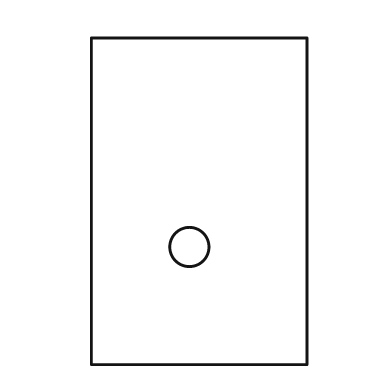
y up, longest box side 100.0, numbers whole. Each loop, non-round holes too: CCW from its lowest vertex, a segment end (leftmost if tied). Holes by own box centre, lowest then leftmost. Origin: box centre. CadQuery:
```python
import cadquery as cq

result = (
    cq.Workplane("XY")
    .moveTo(-33.0, -50.0)
    .lineTo(33.0, -50.0)
    .lineTo(33.0, 50.0)
    .lineTo(-33.0, 50.0)
    .close()
    .moveTo(-3.0, -14.0)
    .circle(6.0)
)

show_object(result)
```